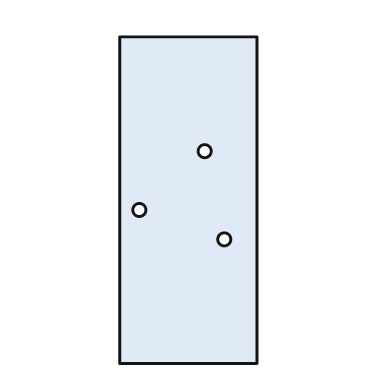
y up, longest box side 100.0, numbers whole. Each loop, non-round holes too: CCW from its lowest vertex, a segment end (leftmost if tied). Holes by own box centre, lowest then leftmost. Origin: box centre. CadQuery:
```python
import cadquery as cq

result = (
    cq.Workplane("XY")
    .moveTo(-21.0, -50.0)
    .lineTo(21.0, -50.0)
    .lineTo(21.0, 50.0)
    .lineTo(-21.0, 50.0)
    .close()
    .moveTo(11.0, -12.0)
    .circle(2.0)
    .moveTo(-15.0, -3.0)
    .circle(2.0)
    .moveTo(5.0, 15.0)
    .circle(2.0)
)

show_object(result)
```